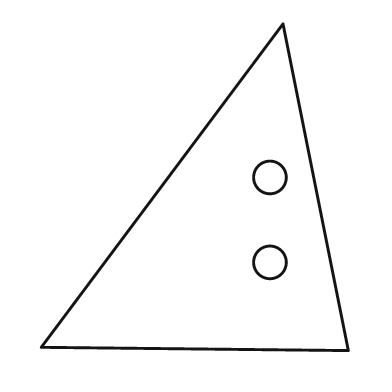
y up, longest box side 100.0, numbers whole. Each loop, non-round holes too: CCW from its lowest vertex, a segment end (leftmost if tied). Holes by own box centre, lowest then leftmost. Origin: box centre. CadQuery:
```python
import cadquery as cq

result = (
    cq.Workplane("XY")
    .moveTo(47.0, -50.0)
    .lineTo(27.0, 50.0)
    .lineTo(-47.0, -49.0)
    .close()
    .moveTo(23.0, -23.0)
    .circle(5.0)
    .moveTo(23.0, 3.0)
    .circle(5.0)
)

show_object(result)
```